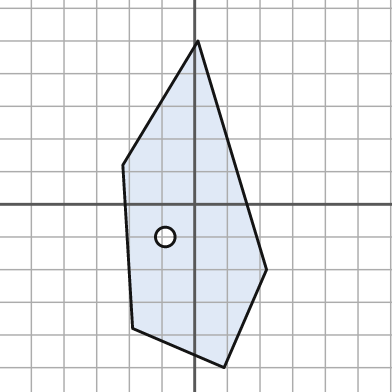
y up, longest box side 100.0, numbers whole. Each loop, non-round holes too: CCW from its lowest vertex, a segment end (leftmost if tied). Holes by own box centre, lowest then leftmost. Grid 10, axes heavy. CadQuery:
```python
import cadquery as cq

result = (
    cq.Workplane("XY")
    .moveTo(9.0, -50.0)
    .lineTo(22.0, -20.0)
    .lineTo(1.0, 50.0)
    .lineTo(-22.0, 12.0)
    .lineTo(-19.0, -38.0)
    .close()
    .moveTo(-9.0, -10.0)
    .circle(3.0)
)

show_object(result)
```